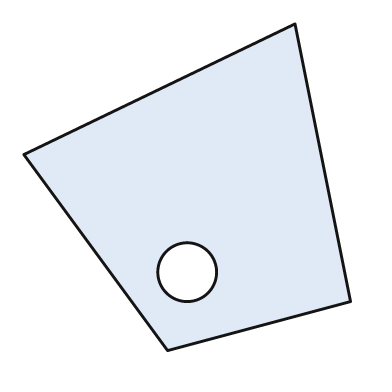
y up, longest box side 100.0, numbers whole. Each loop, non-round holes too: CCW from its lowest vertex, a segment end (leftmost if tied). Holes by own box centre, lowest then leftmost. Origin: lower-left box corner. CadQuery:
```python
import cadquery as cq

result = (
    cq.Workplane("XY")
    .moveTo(44.0, 0.0)
    .lineTo(100.0, 15.0)
    .lineTo(83.0, 100.0)
    .lineTo(0.0, 60.0)
    .close()
    .moveTo(50.0, 24.0)
    .circle(9.0)
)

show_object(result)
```